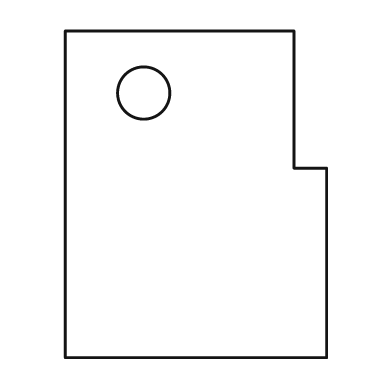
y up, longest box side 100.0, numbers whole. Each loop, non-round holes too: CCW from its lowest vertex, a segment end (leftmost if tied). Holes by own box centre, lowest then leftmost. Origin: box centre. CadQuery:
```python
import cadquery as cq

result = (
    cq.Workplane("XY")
    .moveTo(-40.0, -50.0)
    .lineTo(40.0, -50.0)
    .lineTo(40.0, 8.0)
    .lineTo(30.0, 8.0)
    .lineTo(30.0, 50.0)
    .lineTo(-40.0, 50.0)
    .close()
    .moveTo(-16.0, 31.0)
    .circle(8.0)
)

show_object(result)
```